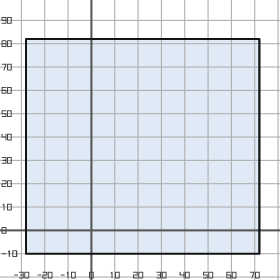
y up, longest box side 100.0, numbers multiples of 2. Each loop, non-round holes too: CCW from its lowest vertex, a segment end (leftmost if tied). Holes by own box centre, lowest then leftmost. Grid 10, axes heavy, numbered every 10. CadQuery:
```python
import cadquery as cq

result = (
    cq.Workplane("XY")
    .moveTo(-28.0, -10.0)
    .lineTo(72.0, -10.0)
    .lineTo(72.0, 82.0)
    .lineTo(-28.0, 82.0)
    .close()
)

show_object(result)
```